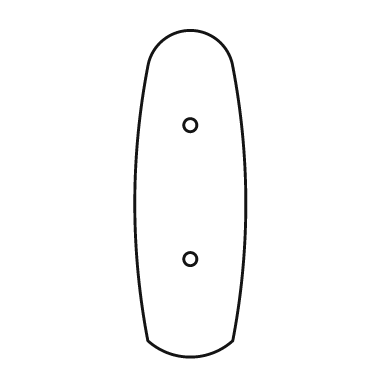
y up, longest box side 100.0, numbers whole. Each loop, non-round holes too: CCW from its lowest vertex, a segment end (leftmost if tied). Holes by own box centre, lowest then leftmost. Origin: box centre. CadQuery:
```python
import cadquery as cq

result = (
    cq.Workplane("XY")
    .moveTo(-13.0, -45.0)
    .threePointArc((0.0, -50.0), (13.0, -45.0))
    .threePointArc((17.0, -3.0), (13.0, 39.0))
    .threePointArc((0.0, 50.0), (-13.0, 39.0))
    .threePointArc((-17.0, -3.0), (-13.0, -45.0))
    .close()
    .moveTo(0.0, -20.0)
    .circle(2.0)
    .moveTo(0.0, 21.0)
    .circle(2.0)
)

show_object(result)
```